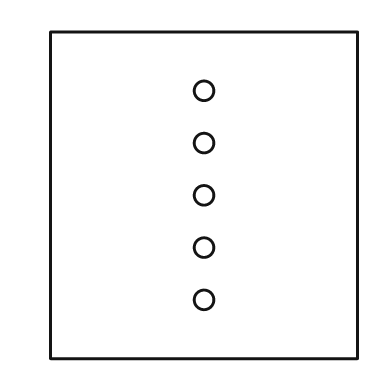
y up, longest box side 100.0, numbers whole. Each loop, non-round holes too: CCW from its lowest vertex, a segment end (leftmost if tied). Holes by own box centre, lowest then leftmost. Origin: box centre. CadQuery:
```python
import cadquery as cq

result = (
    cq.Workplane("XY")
    .moveTo(-47.0, -50.0)
    .lineTo(47.0, -50.0)
    .lineTo(47.0, 50.0)
    .lineTo(-47.0, 50.0)
    .close()
    .moveTo(0.0, -32.0)
    .circle(3.0)
    .moveTo(0.0, -16.0)
    .circle(3.0)
    .moveTo(0.0, 0.0)
    .circle(3.0)
    .moveTo(0.0, 16.0)
    .circle(3.0)
    .moveTo(0.0, 32.0)
    .circle(3.0)
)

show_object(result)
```